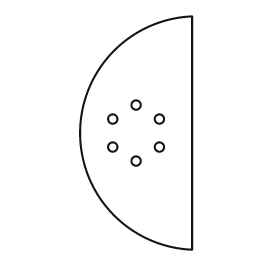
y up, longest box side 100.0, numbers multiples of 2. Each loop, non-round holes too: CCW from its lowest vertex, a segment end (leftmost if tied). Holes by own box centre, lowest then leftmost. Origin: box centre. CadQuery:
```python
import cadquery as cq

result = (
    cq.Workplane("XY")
    .moveTo(24.0, -50.0)
    .lineTo(24.0, 50.0)
    .threePointArc((-24.0, 0.0), (24.0, -50.0))
    .close()
    .moveTo(0.0, -12.0)
    .circle(2.0)
    .moveTo(-10.0, -6.0)
    .circle(2.0)
    .moveTo(10.0, -6.0)
    .circle(2.0)
    .moveTo(-10.0, 6.0)
    .circle(2.0)
    .moveTo(10.0, 6.0)
    .circle(2.0)
    .moveTo(0.0, 12.0)
    .circle(2.0)
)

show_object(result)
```